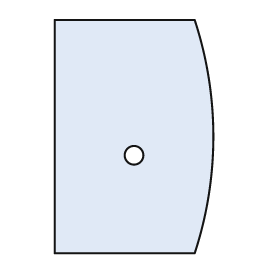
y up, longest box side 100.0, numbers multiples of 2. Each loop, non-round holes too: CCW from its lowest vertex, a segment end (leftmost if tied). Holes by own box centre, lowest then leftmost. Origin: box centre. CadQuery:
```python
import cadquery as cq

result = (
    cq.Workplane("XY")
    .moveTo(-34.0, -50.0)
    .lineTo(26.0, -50.0)
    .threePointArc((34.0, 0.0), (26.0, 50.0))
    .lineTo(-34.0, 50.0)
    .close()
    .moveTo(0.0, -8.0)
    .circle(4.0)
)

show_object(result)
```